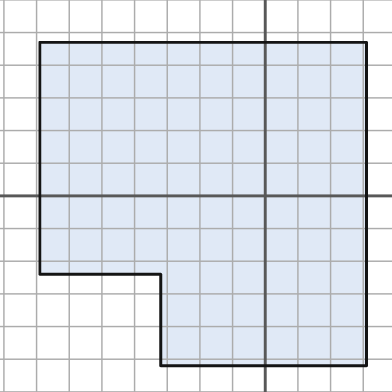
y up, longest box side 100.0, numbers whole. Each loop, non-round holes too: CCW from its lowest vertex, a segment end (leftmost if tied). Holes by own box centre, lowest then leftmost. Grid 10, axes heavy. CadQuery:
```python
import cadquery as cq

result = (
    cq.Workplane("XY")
    .moveTo(-32.0, -52.0)
    .lineTo(31.0, -52.0)
    .lineTo(31.0, 47.0)
    .lineTo(-69.0, 47.0)
    .lineTo(-69.0, -24.0)
    .lineTo(-32.0, -24.0)
    .close()
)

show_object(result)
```